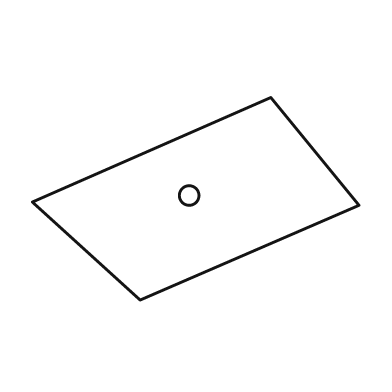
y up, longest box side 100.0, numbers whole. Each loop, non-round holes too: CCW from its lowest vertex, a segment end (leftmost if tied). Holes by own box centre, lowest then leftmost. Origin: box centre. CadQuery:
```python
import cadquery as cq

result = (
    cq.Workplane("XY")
    .moveTo(-17.0, -31.0)
    .lineTo(50.0, -2.0)
    .lineTo(23.0, 31.0)
    .lineTo(-50.0, -1.0)
    .close()
    .moveTo(-2.0, 1.0)
    .circle(3.0)
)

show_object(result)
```